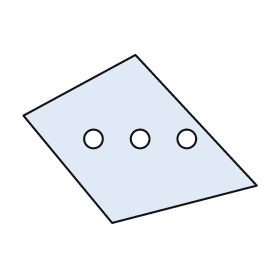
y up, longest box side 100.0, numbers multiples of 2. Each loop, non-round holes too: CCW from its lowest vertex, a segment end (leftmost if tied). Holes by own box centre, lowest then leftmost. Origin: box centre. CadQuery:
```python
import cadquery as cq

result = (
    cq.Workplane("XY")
    .moveTo(-12.0, -36.0)
    .lineTo(50.0, -20.0)
    .lineTo(-2.0, 36.0)
    .lineTo(-50.0, 10.0)
    .close()
    .moveTo(-20.0, 0.0)
    .circle(4.0)
    .moveTo(0.0, 0.0)
    .circle(4.0)
    .moveTo(20.0, 0.0)
    .circle(4.0)
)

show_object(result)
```